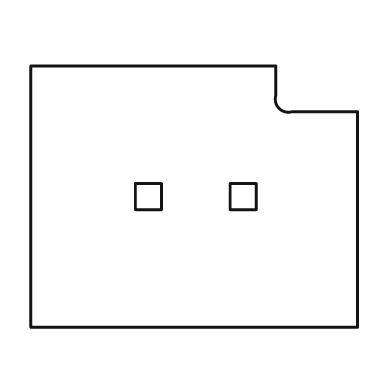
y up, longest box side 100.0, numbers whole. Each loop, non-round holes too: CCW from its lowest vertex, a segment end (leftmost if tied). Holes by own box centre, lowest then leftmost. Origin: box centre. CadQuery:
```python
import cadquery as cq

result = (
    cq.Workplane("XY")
    .moveTo(-50.0, -40.0)
    .lineTo(50.0, -40.0)
    .lineTo(50.0, 26.0)
    .lineTo(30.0, 26.0)
    .threePointArc((26.0, 27.0), (25.0, 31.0))
    .lineTo(25.0, 40.0)
    .lineTo(-50.0, 40.0)
    .close()
    .moveTo(-18.0, -4.0)
    .lineTo(-10.0, -4.0)
    .lineTo(-10.0, 4.0)
    .lineTo(-18.0, 4.0)
    .close()
    .moveTo(11.0, -4.0)
    .lineTo(19.0, -4.0)
    .lineTo(19.0, 4.0)
    .lineTo(11.0, 4.0)
    .close()
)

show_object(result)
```